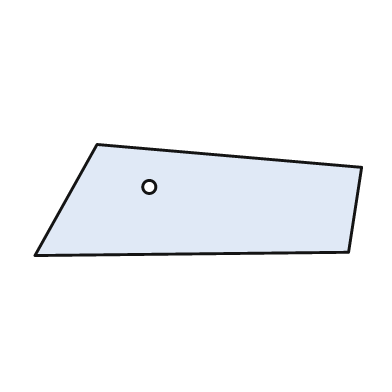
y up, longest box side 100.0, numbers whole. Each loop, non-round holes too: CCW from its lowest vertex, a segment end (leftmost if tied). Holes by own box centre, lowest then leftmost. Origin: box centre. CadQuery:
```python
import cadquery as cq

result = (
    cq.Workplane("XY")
    .moveTo(-50.0, -17.0)
    .lineTo(46.0, -16.0)
    .lineTo(50.0, 10.0)
    .lineTo(-31.0, 17.0)
    .close()
    .moveTo(-15.0, 4.0)
    .circle(2.0)
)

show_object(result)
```